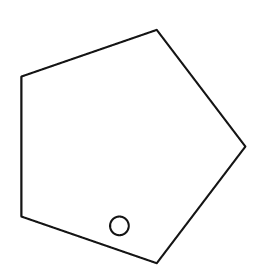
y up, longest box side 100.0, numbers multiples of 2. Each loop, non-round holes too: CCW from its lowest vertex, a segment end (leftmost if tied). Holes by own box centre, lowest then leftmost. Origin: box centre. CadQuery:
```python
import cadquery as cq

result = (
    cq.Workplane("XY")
    .moveTo(10.0, -50.0)
    .lineTo(48.0, 0.0)
    .lineTo(10.0, 50.0)
    .lineTo(-48.0, 30.0)
    .lineTo(-48.0, -30.0)
    .close()
    .moveTo(-6.0, -34.0)
    .circle(4.0)
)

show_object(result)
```